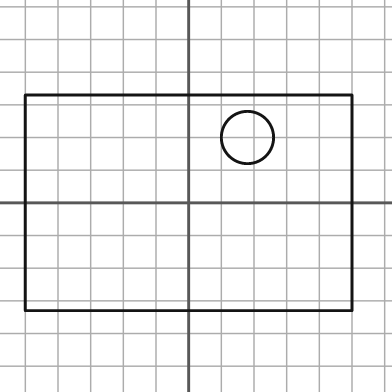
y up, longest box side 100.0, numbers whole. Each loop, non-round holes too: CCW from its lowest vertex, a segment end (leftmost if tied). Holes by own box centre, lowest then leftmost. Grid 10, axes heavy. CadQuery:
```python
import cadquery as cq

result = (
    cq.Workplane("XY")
    .moveTo(-50.0, -33.0)
    .lineTo(50.0, -33.0)
    .lineTo(50.0, 33.0)
    .lineTo(-50.0, 33.0)
    .close()
    .moveTo(18.0, 20.0)
    .circle(8.0)
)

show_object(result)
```